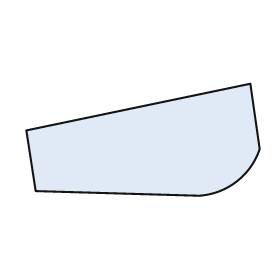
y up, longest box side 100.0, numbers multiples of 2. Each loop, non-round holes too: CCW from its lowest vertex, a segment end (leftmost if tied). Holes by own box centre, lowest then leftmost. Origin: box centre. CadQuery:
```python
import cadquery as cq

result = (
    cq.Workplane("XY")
    .moveTo(24.0, -24.0)
    .threePointArc((40.0, -18.0), (50.0, -4.0))
    .lineTo(46.0, 24.0)
    .lineTo(-50.0, 4.0)
    .lineTo(-46.0, -22.0)
    .close()
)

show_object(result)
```